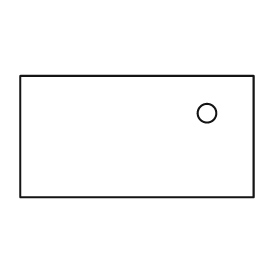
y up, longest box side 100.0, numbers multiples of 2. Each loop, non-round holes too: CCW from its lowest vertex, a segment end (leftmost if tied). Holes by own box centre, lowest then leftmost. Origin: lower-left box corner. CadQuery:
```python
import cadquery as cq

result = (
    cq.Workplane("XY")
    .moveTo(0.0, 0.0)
    .lineTo(100.0, 0.0)
    .lineTo(100.0, 52.0)
    .lineTo(0.0, 52.0)
    .close()
    .moveTo(80.0, 36.0)
    .circle(4.0)
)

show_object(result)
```